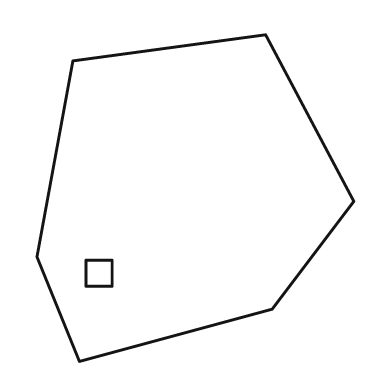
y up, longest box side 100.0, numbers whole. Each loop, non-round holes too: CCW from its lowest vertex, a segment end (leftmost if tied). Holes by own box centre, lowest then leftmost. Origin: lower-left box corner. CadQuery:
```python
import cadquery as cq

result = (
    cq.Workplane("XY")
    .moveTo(13.0, 0.0)
    .lineTo(72.0, 16.0)
    .lineTo(97.0, 49.0)
    .lineTo(70.0, 100.0)
    .lineTo(11.0, 92.0)
    .lineTo(0.0, 32.0)
    .close()
    .moveTo(15.0, 23.0)
    .lineTo(23.0, 23.0)
    .lineTo(23.0, 31.0)
    .lineTo(15.0, 31.0)
    .close()
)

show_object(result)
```